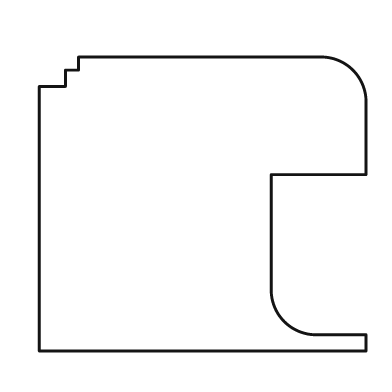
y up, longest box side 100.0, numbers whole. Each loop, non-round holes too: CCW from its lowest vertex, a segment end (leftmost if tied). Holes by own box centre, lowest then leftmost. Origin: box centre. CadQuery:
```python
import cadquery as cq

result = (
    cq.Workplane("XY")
    .moveTo(-50.0, -45.0)
    .lineTo(50.0, -45.0)
    .lineTo(50.0, -40.0)
    .lineTo(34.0, -40.0)
    .threePointArc((25.0, -36.0), (21.0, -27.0))
    .lineTo(21.0, 9.0)
    .lineTo(50.0, 9.0)
    .lineTo(50.0, 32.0)
    .threePointArc((46.0, 41.0), (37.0, 45.0))
    .lineTo(-38.0, 45.0)
    .lineTo(-38.0, 41.0)
    .lineTo(-42.0, 41.0)
    .lineTo(-42.0, 36.0)
    .lineTo(-50.0, 36.0)
    .close()
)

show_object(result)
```